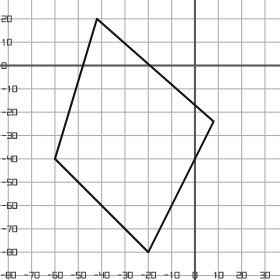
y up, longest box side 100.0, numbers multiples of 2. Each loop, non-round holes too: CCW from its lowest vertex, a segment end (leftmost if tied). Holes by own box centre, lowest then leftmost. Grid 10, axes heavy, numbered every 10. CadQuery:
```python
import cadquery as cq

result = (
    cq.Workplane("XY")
    .moveTo(-20.0, -80.0)
    .lineTo(8.0, -24.0)
    .lineTo(-42.0, 20.0)
    .lineTo(-60.0, -40.0)
    .close()
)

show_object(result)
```